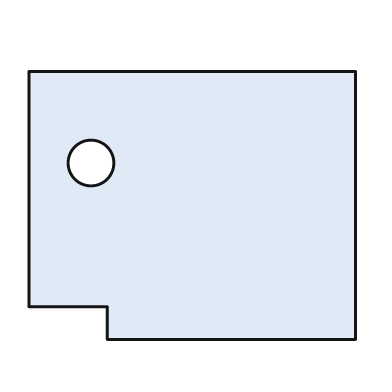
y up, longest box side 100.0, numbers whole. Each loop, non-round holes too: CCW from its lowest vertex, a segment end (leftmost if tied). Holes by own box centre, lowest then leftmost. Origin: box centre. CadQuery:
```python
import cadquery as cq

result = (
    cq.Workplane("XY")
    .moveTo(-26.0, -41.0)
    .lineTo(50.0, -41.0)
    .lineTo(50.0, 41.0)
    .lineTo(-50.0, 41.0)
    .lineTo(-50.0, -31.0)
    .lineTo(-26.0, -31.0)
    .close()
    .moveTo(-31.0, 13.0)
    .circle(7.0)
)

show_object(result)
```